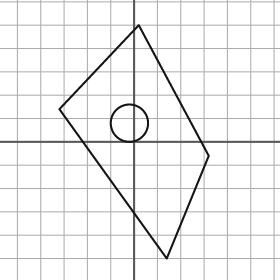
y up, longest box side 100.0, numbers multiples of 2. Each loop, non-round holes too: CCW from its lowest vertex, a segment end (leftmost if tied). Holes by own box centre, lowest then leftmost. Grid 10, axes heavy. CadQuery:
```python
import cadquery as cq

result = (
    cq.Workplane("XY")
    .moveTo(14.0, -50.0)
    .lineTo(32.0, -6.0)
    .lineTo(2.0, 50.0)
    .lineTo(-32.0, 14.0)
    .close()
    .moveTo(-2.0, 8.0)
    .circle(8.0)
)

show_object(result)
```